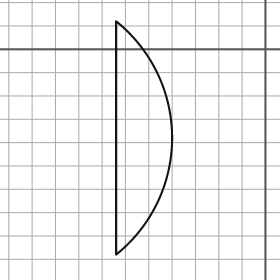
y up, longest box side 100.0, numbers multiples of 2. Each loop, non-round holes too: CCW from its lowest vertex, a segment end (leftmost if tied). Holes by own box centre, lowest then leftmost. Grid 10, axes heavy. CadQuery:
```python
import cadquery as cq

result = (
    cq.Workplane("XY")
    .moveTo(-64.0, -88.0)
    .threePointArc((-40.0, -38.0), (-64.0, 12.0))
    .close()
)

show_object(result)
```